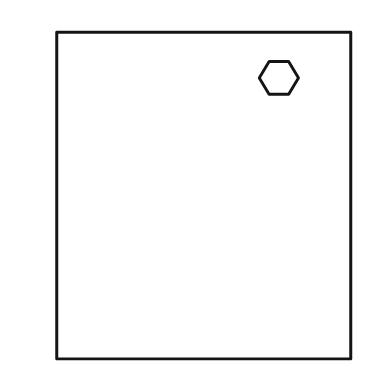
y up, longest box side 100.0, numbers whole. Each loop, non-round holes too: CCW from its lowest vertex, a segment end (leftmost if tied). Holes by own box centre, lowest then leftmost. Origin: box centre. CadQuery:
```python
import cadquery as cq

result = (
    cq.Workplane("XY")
    .moveTo(-45.0, -50.0)
    .lineTo(45.0, -50.0)
    .lineTo(45.0, 50.0)
    .lineTo(-45.0, 50.0)
    .close()
    .moveTo(20.0, 31.0)
    .lineTo(26.0, 31.0)
    .lineTo(29.0, 36.0)
    .lineTo(26.0, 41.0)
    .lineTo(20.0, 41.0)
    .lineTo(17.0, 36.0)
    .close()
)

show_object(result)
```